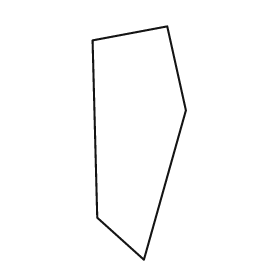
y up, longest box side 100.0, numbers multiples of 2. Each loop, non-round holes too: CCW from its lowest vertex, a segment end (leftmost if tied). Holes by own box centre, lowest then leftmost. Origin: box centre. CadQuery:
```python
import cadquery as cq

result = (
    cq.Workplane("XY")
    .moveTo(2.0, -50.0)
    .lineTo(20.0, 14.0)
    .lineTo(12.0, 50.0)
    .lineTo(-20.0, 44.0)
    .lineTo(-18.0, -32.0)
    .close()
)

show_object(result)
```